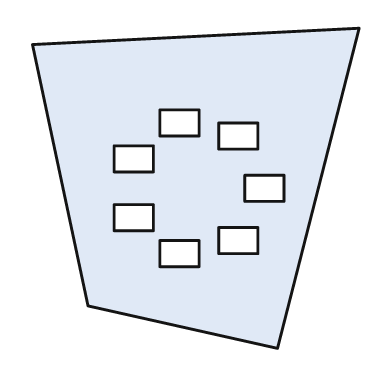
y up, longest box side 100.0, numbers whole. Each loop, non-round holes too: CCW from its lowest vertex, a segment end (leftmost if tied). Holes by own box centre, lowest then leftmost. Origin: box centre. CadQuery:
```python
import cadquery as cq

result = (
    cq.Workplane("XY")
    .moveTo(25.0, -49.0)
    .lineTo(50.0, 49.0)
    .lineTo(-50.0, 44.0)
    .lineTo(-33.0, -36.0)
    .close()
    .moveTo(-11.0, -24.0)
    .lineTo(1.0, -24.0)
    .lineTo(1.0, -16.0)
    .lineTo(-11.0, -16.0)
    .close()
    .moveTo(7.0, -20.0)
    .lineTo(19.0, -20.0)
    .lineTo(19.0, -12.0)
    .lineTo(7.0, -12.0)
    .close()
    .moveTo(-25.0, -13.0)
    .lineTo(-13.0, -13.0)
    .lineTo(-13.0, -5.0)
    .lineTo(-25.0, -5.0)
    .close()
    .moveTo(15.0, -4.0)
    .lineTo(27.0, -4.0)
    .lineTo(27.0, 4.0)
    .lineTo(15.0, 4.0)
    .close()
    .moveTo(-25.0, 5.0)
    .lineTo(-13.0, 5.0)
    .lineTo(-13.0, 13.0)
    .lineTo(-25.0, 13.0)
    .close()
    .moveTo(7.0, 12.0)
    .lineTo(19.0, 12.0)
    .lineTo(19.0, 20.0)
    .lineTo(7.0, 20.0)
    .close()
    .moveTo(-11.0, 16.0)
    .lineTo(1.0, 16.0)
    .lineTo(1.0, 24.0)
    .lineTo(-11.0, 24.0)
    .close()
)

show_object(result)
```